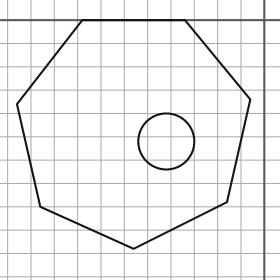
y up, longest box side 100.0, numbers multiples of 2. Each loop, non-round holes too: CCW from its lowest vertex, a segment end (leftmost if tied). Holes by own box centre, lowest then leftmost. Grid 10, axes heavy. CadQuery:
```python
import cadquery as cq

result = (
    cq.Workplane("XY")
    .moveTo(-56.0, -98.0)
    .lineTo(-16.0, -78.0)
    .lineTo(-6.0, -34.0)
    .lineTo(-34.0, 0.0)
    .lineTo(-78.0, 0.0)
    .lineTo(-106.0, -36.0)
    .lineTo(-96.0, -80.0)
    .close()
    .moveTo(-42.0, -52.0)
    .circle(12.0)
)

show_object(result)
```